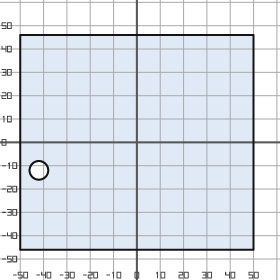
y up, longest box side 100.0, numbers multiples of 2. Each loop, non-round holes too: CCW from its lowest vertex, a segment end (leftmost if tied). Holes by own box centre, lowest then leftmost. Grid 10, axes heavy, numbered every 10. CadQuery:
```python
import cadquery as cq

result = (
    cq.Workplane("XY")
    .moveTo(-50.0, -46.0)
    .lineTo(50.0, -46.0)
    .lineTo(50.0, 46.0)
    .lineTo(-50.0, 46.0)
    .close()
    .moveTo(-42.0, -12.0)
    .circle(4.0)
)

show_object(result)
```